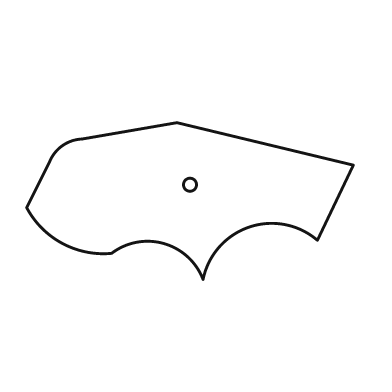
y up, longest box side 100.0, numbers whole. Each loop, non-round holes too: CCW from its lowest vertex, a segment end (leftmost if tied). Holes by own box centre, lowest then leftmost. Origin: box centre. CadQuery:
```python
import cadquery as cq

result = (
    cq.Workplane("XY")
    .moveTo(4.0, -24.0)
    .threePointArc((18.0, -8.0), (39.0, -12.0))
    .lineTo(50.0, 11.0)
    .lineTo(-4.0, 24.0)
    .lineTo(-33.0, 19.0)
    .threePointArc((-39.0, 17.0), (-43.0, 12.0))
    .lineTo(-50.0, -2.0)
    .threePointArc((-39.0, -13.0), (-24.0, -16.0))
    .threePointArc((-8.0, -13.0), (4.0, -24.0))
    .close()
    .moveTo(0.0, 5.0)
    .circle(2.0)
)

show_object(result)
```